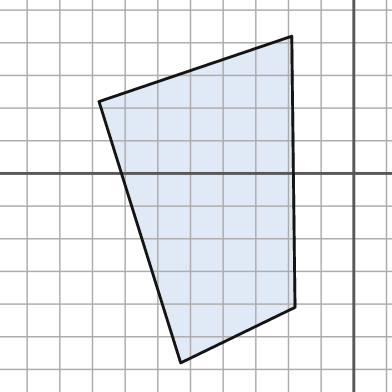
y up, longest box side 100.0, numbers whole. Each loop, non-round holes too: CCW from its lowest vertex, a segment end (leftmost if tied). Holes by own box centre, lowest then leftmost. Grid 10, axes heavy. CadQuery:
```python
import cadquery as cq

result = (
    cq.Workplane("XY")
    .moveTo(-53.0, -58.0)
    .lineTo(-18.0, -41.0)
    .lineTo(-19.0, 42.0)
    .lineTo(-78.0, 22.0)
    .close()
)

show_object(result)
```